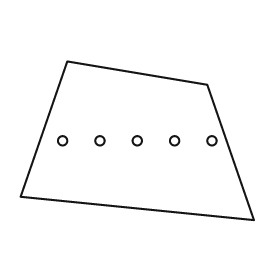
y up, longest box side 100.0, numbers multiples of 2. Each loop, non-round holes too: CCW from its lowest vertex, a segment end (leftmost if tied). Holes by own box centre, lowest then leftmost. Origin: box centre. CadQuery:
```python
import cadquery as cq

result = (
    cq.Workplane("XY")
    .moveTo(50.0, -34.0)
    .lineTo(30.0, 24.0)
    .lineTo(-30.0, 34.0)
    .lineTo(-50.0, -24.0)
    .close()
    .moveTo(-32.0, 0.0)
    .circle(2.0)
    .moveTo(-16.0, 0.0)
    .circle(2.0)
    .moveTo(0.0, 0.0)
    .circle(2.0)
    .moveTo(16.0, 0.0)
    .circle(2.0)
    .moveTo(32.0, 0.0)
    .circle(2.0)
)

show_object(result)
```